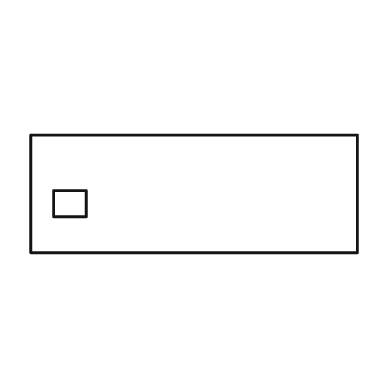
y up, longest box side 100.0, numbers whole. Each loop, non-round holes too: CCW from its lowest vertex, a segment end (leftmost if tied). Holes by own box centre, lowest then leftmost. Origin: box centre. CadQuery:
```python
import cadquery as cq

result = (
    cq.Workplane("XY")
    .moveTo(-50.0, -18.0)
    .lineTo(50.0, -18.0)
    .lineTo(50.0, 18.0)
    .lineTo(-50.0, 18.0)
    .close()
    .moveTo(-43.0, -7.0)
    .lineTo(-33.0, -7.0)
    .lineTo(-33.0, 1.0)
    .lineTo(-43.0, 1.0)
    .close()
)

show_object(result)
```